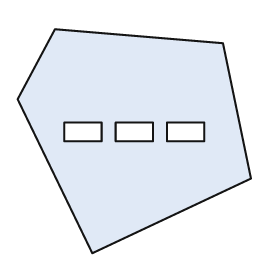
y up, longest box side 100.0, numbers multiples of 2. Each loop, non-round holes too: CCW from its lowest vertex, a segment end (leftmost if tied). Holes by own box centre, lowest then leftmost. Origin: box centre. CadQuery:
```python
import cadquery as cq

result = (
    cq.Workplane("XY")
    .moveTo(-18.0, -48.0)
    .lineTo(50.0, -16.0)
    .lineTo(38.0, 42.0)
    .lineTo(-34.0, 48.0)
    .lineTo(-50.0, 18.0)
    .close()
    .moveTo(-30.0, 0.0)
    .lineTo(-14.0, 0.0)
    .lineTo(-14.0, 8.0)
    .lineTo(-30.0, 8.0)
    .close()
    .moveTo(-8.0, 0.0)
    .lineTo(8.0, 0.0)
    .lineTo(8.0, 8.0)
    .lineTo(-8.0, 8.0)
    .close()
    .moveTo(14.0, 0.0)
    .lineTo(30.0, 0.0)
    .lineTo(30.0, 8.0)
    .lineTo(14.0, 8.0)
    .close()
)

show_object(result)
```